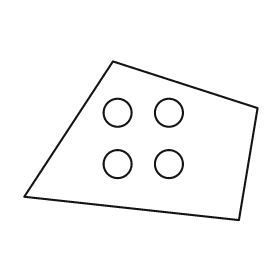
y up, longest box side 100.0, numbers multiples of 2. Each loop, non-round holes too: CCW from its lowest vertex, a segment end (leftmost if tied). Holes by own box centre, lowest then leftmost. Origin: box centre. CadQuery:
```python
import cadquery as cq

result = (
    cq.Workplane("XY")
    .moveTo(42.0, -34.0)
    .lineTo(50.0, 14.0)
    .lineTo(-12.0, 34.0)
    .lineTo(-50.0, -24.0)
    .close()
    .moveTo(-10.0, -10.0)
    .circle(6.0)
    .moveTo(12.0, -10.0)
    .circle(6.0)
    .moveTo(-10.0, 12.0)
    .circle(6.0)
    .moveTo(12.0, 12.0)
    .circle(6.0)
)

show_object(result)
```